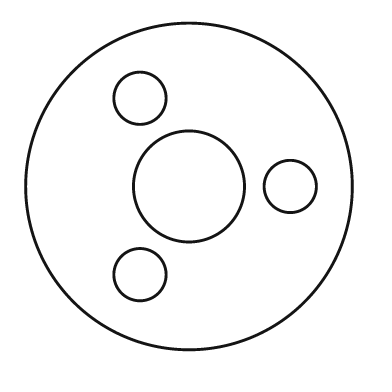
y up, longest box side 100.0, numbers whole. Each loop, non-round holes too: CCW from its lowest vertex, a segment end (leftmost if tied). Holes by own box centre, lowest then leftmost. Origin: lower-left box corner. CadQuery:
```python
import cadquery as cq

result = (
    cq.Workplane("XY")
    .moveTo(50.0, 50.0)
    .circle(50.0)
    .moveTo(35.0, 23.0)
    .circle(8.0)
    .moveTo(50.0, 50.0)
    .circle(17.0)
    .moveTo(81.0, 50.0)
    .circle(8.0)
    .moveTo(35.0, 77.0)
    .circle(8.0)
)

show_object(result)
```